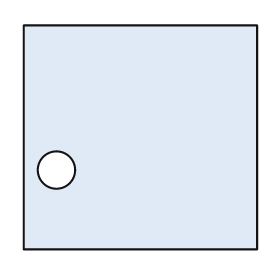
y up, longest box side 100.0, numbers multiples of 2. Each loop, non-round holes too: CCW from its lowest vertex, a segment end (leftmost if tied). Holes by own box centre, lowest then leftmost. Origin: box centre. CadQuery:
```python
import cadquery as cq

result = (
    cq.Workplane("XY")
    .moveTo(-50.0, -48.0)
    .lineTo(50.0, -48.0)
    .lineTo(50.0, 48.0)
    .lineTo(-50.0, 48.0)
    .close()
    .moveTo(-36.0, -14.0)
    .circle(8.0)
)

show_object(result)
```